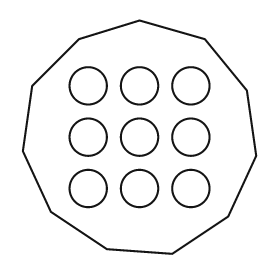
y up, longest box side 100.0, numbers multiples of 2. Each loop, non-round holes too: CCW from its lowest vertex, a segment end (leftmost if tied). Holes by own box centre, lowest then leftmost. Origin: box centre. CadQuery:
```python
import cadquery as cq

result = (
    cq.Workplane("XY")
    .moveTo(14.0, -50.0)
    .lineTo(38.0, -34.0)
    .lineTo(50.0, -8.0)
    .lineTo(46.0, 20.0)
    .lineTo(28.0, 42.0)
    .lineTo(0.0, 50.0)
    .lineTo(-26.0, 42.0)
    .lineTo(-46.0, 22.0)
    .lineTo(-50.0, -6.0)
    .lineTo(-38.0, -32.0)
    .lineTo(-14.0, -48.0)
    .close()
    .moveTo(-22.0, -22.0)
    .circle(8.0)
    .moveTo(0.0, -22.0)
    .circle(8.0)
    .moveTo(22.0, -22.0)
    .circle(8.0)
    .moveTo(-22.0, 0.0)
    .circle(8.0)
    .moveTo(0.0, 0.0)
    .circle(8.0)
    .moveTo(22.0, 0.0)
    .circle(8.0)
    .moveTo(-22.0, 22.0)
    .circle(8.0)
    .moveTo(0.0, 22.0)
    .circle(8.0)
    .moveTo(22.0, 22.0)
    .circle(8.0)
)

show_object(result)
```